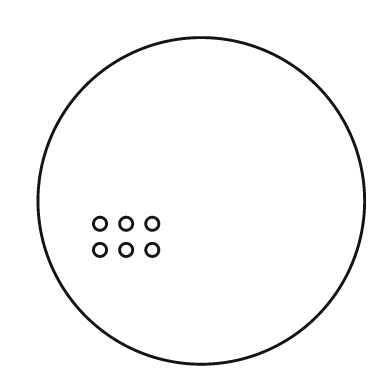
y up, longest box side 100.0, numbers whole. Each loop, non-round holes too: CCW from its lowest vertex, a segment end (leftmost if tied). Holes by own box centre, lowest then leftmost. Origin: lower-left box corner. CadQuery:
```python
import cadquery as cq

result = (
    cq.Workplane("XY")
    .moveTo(50.0, 50.0)
    .circle(50.0)
    .moveTo(19.0, 35.0)
    .circle(2.0)
    .moveTo(27.0, 35.0)
    .circle(2.0)
    .moveTo(35.0, 35.0)
    .circle(2.0)
    .moveTo(19.0, 43.0)
    .circle(2.0)
    .moveTo(27.0, 43.0)
    .circle(2.0)
    .moveTo(35.0, 43.0)
    .circle(2.0)
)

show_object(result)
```